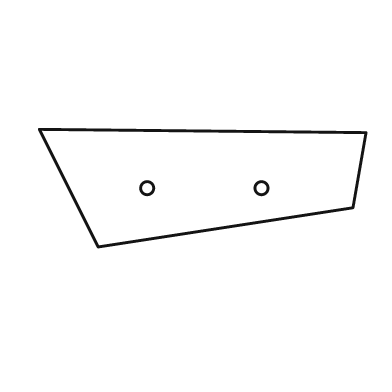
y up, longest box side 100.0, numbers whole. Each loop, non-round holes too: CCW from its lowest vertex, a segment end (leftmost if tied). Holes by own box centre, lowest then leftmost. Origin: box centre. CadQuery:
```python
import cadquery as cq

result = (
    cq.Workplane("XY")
    .moveTo(-32.0, -18.0)
    .lineTo(46.0, -6.0)
    .lineTo(50.0, 17.0)
    .lineTo(-50.0, 18.0)
    .close()
    .moveTo(-17.0, 0.0)
    .circle(2.0)
    .moveTo(18.0, 0.0)
    .circle(2.0)
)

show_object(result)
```